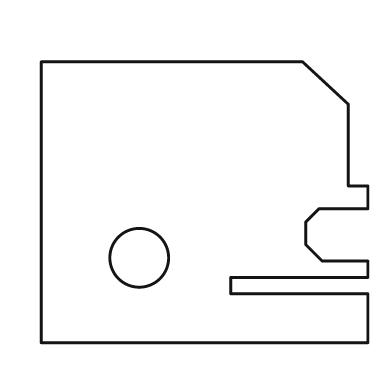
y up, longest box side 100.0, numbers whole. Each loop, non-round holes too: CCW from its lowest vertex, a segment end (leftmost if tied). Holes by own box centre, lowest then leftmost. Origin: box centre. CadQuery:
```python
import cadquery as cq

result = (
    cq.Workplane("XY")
    .moveTo(-50.0, -43.0)
    .lineTo(50.0, -43.0)
    .lineTo(50.0, -28.0)
    .lineTo(8.0, -28.0)
    .lineTo(8.0, -23.0)
    .lineTo(50.0, -23.0)
    .lineTo(50.0, -18.0)
    .lineTo(36.0, -18.0)
    .lineTo(31.0, -13.0)
    .lineTo(31.0, -6.0)
    .lineTo(35.0, -2.0)
    .lineTo(50.0, -2.0)
    .lineTo(50.0, 5.0)
    .lineTo(44.0, 5.0)
    .lineTo(44.0, 30.0)
    .lineTo(30.0, 43.0)
    .lineTo(-50.0, 43.0)
    .close()
    .moveTo(-20.0, -17.0)
    .circle(9.0)
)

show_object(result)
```